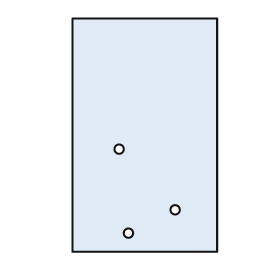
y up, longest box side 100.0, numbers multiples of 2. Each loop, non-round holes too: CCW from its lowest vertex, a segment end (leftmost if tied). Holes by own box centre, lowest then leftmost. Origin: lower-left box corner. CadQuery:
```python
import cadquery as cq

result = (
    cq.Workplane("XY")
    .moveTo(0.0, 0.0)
    .lineTo(62.0, 0.0)
    .lineTo(62.0, 100.0)
    .lineTo(0.0, 100.0)
    .close()
    .moveTo(24.0, 8.0)
    .circle(2.0)
    .moveTo(44.0, 18.0)
    .circle(2.0)
    .moveTo(20.0, 44.0)
    .circle(2.0)
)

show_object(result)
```